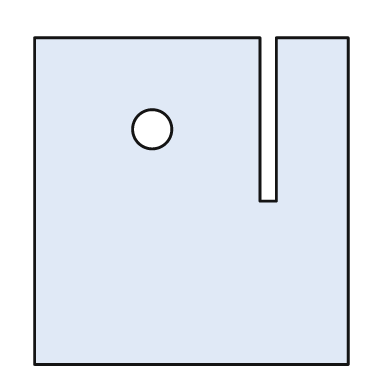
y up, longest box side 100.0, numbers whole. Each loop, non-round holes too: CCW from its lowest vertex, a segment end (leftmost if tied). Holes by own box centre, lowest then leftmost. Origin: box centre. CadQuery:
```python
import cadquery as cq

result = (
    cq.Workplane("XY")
    .moveTo(-48.0, -50.0)
    .lineTo(48.0, -50.0)
    .lineTo(48.0, 50.0)
    .lineTo(26.0, 50.0)
    .lineTo(26.0, 0.0)
    .lineTo(21.0, 0.0)
    .lineTo(21.0, 50.0)
    .lineTo(-48.0, 50.0)
    .close()
    .moveTo(-12.0, 22.0)
    .circle(6.0)
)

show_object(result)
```